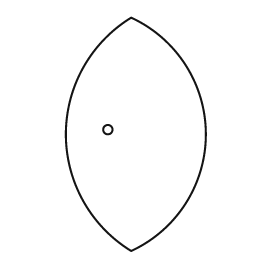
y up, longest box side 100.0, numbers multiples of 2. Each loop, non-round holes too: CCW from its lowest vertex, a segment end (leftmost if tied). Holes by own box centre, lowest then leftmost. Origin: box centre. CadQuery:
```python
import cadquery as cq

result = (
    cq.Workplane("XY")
    .moveTo(-2.0, -50.0)
    .threePointArc((30.0, 0.0), (-2.0, 50.0))
    .threePointArc((-30.0, 0.0), (-2.0, -50.0))
    .close()
    .moveTo(-12.0, 2.0)
    .circle(2.0)
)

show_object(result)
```